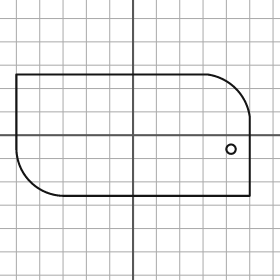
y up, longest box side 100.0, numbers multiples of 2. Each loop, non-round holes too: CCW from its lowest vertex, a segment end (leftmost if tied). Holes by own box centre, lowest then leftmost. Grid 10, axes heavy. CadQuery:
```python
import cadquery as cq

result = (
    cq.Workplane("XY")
    .moveTo(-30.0, -26.0)
    .lineTo(50.0, -26.0)
    .lineTo(50.0, 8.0)
    .threePointArc((44.0, 20.0), (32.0, 26.0))
    .lineTo(-50.0, 26.0)
    .lineTo(-50.0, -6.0)
    .threePointArc((-44.0, -20.0), (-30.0, -26.0))
    .close()
    .moveTo(42.0, -6.0)
    .circle(2.0)
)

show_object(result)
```